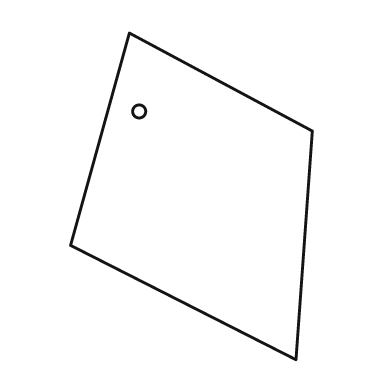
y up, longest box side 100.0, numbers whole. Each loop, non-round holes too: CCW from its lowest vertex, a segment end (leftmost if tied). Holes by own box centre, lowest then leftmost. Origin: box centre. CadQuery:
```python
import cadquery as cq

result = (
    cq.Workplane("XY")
    .moveTo(32.0, -50.0)
    .lineTo(37.0, 20.0)
    .lineTo(-19.0, 50.0)
    .lineTo(-37.0, -15.0)
    .close()
    .moveTo(-16.0, 26.0)
    .circle(2.0)
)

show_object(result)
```